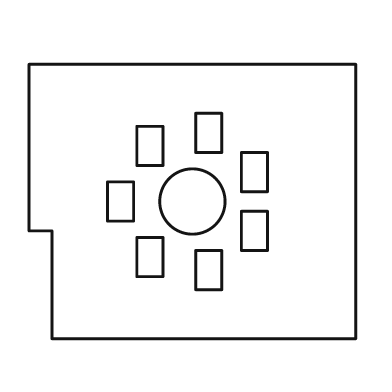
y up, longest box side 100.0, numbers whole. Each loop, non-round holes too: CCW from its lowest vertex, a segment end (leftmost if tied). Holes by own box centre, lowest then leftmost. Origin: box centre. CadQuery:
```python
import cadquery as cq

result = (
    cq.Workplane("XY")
    .moveTo(-43.0, -42.0)
    .lineTo(50.0, -42.0)
    .lineTo(50.0, 42.0)
    .lineTo(-50.0, 42.0)
    .lineTo(-50.0, -9.0)
    .lineTo(-43.0, -9.0)
    .close()
    .moveTo(1.0, -27.0)
    .lineTo(9.0, -27.0)
    .lineTo(9.0, -15.0)
    .lineTo(1.0, -15.0)
    .close()
    .moveTo(-17.0, -23.0)
    .lineTo(-9.0, -23.0)
    .lineTo(-9.0, -11.0)
    .lineTo(-17.0, -11.0)
    .close()
    .moveTo(15.0, -15.0)
    .lineTo(23.0, -15.0)
    .lineTo(23.0, -3.0)
    .lineTo(15.0, -3.0)
    .close()
    .moveTo(-26.0, -6.0)
    .lineTo(-18.0, -6.0)
    .lineTo(-18.0, 6.0)
    .lineTo(-26.0, 6.0)
    .close()
    .moveTo(0.0, 0.0)
    .circle(10.0)
    .moveTo(15.0, 3.0)
    .lineTo(23.0, 3.0)
    .lineTo(23.0, 15.0)
    .lineTo(15.0, 15.0)
    .close()
    .moveTo(-17.0, 11.0)
    .lineTo(-9.0, 11.0)
    .lineTo(-9.0, 23.0)
    .lineTo(-17.0, 23.0)
    .close()
    .moveTo(1.0, 15.0)
    .lineTo(9.0, 15.0)
    .lineTo(9.0, 27.0)
    .lineTo(1.0, 27.0)
    .close()
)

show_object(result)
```